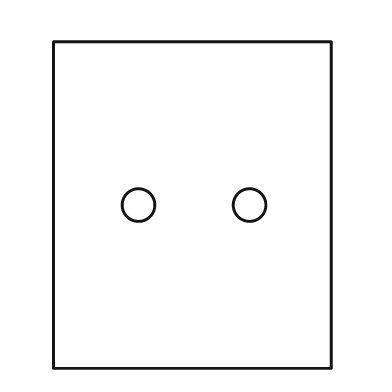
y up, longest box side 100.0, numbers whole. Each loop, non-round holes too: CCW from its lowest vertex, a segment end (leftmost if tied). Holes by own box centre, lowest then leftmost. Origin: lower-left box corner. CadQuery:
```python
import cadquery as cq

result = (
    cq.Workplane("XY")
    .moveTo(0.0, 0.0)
    .lineTo(85.0, 0.0)
    .lineTo(85.0, 100.0)
    .lineTo(0.0, 100.0)
    .close()
    .moveTo(26.0, 50.0)
    .circle(5.0)
    .moveTo(60.0, 50.0)
    .circle(5.0)
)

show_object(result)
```